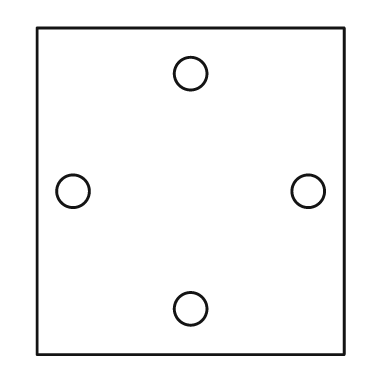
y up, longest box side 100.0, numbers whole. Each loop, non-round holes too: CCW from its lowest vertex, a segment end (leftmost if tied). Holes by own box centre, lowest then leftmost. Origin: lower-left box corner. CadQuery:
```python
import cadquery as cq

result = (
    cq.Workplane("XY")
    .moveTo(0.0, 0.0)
    .lineTo(94.0, 0.0)
    .lineTo(94.0, 100.0)
    .lineTo(0.0, 100.0)
    .close()
    .moveTo(47.0, 14.0)
    .circle(5.0)
    .moveTo(11.0, 50.0)
    .circle(5.0)
    .moveTo(83.0, 50.0)
    .circle(5.0)
    .moveTo(47.0, 86.0)
    .circle(5.0)
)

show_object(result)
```